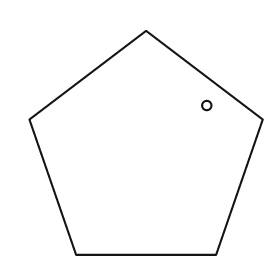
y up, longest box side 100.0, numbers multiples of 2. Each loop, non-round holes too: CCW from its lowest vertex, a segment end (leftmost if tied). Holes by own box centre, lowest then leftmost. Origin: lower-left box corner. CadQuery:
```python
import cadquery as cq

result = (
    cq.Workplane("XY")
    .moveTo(20.0, 0.0)
    .lineTo(80.0, 0.0)
    .lineTo(100.0, 58.0)
    .lineTo(50.0, 96.0)
    .lineTo(0.0, 58.0)
    .close()
    .moveTo(76.0, 64.0)
    .circle(2.0)
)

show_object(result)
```